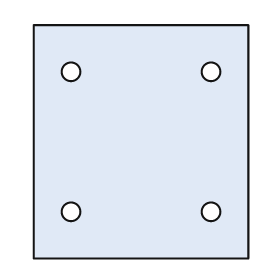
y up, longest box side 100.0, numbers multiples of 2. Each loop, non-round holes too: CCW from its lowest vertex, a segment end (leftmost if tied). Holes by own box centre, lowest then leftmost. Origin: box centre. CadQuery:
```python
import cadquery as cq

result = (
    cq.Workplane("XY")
    .moveTo(-46.0, -50.0)
    .lineTo(46.0, -50.0)
    .lineTo(46.0, 50.0)
    .lineTo(-46.0, 50.0)
    .close()
    .moveTo(-30.0, -30.0)
    .circle(4.0)
    .moveTo(30.0, -30.0)
    .circle(4.0)
    .moveTo(-30.0, 30.0)
    .circle(4.0)
    .moveTo(30.0, 30.0)
    .circle(4.0)
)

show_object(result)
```